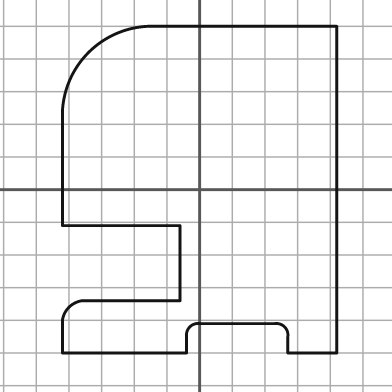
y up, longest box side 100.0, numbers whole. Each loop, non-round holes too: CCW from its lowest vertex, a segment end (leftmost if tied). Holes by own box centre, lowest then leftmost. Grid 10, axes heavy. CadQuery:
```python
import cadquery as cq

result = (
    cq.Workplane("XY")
    .moveTo(-42.0, -50.0)
    .lineTo(-4.0, -50.0)
    .lineTo(-4.0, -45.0)
    .threePointArc((-3.0, -42.0), (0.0, -41.0))
    .lineTo(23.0, -41.0)
    .threePointArc((26.0, -42.0), (27.0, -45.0))
    .lineTo(27.0, -50.0)
    .lineTo(42.0, -50.0)
    .lineTo(42.0, 50.0)
    .lineTo(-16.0, 50.0)
    .threePointArc((-34.0, 42.0), (-42.0, 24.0))
    .lineTo(-42.0, -11.0)
    .lineTo(-6.0, -11.0)
    .lineTo(-6.0, -34.0)
    .lineTo(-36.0, -34.0)
    .threePointArc((-40.0, -36.0), (-42.0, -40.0))
    .close()
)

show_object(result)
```